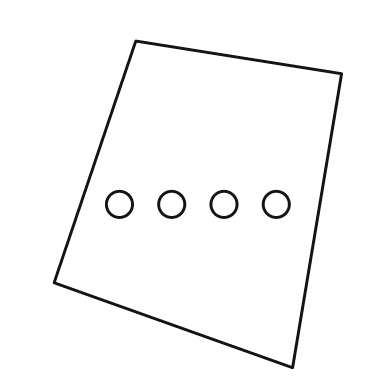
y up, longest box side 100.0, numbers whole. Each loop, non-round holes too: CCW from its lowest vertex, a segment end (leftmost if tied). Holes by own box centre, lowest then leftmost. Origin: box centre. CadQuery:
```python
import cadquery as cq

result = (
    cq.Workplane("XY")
    .moveTo(29.0, -50.0)
    .lineTo(44.0, 40.0)
    .lineTo(-19.0, 50.0)
    .lineTo(-44.0, -24.0)
    .close()
    .moveTo(-24.0, 0.0)
    .circle(4.0)
    .moveTo(-8.0, 0.0)
    .circle(4.0)
    .moveTo(8.0, 0.0)
    .circle(4.0)
    .moveTo(24.0, 0.0)
    .circle(4.0)
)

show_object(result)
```